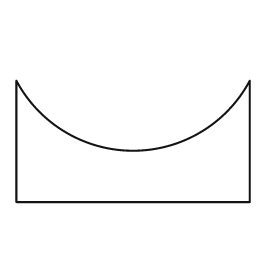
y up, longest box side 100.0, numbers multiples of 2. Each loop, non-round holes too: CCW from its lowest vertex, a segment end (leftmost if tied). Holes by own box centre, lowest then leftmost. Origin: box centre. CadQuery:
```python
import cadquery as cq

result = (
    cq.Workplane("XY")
    .moveTo(-50.0, -26.0)
    .lineTo(50.0, -26.0)
    .lineTo(50.0, 26.0)
    .threePointArc((0.0, -4.0), (-50.0, 26.0))
    .close()
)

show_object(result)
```